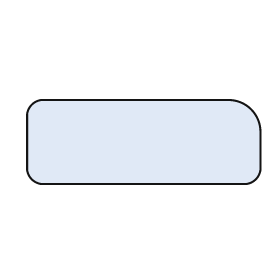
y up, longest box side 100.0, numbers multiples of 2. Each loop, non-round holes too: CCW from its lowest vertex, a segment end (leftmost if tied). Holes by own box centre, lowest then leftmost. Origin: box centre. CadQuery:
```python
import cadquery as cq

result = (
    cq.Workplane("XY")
    .moveTo(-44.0, -18.0)
    .lineTo(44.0, -18.0)
    .threePointArc((48.0, -16.0), (50.0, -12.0))
    .lineTo(50.0, 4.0)
    .threePointArc((46.0, 14.0), (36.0, 18.0))
    .lineTo(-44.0, 18.0)
    .threePointArc((-48.0, 16.0), (-50.0, 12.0))
    .lineTo(-50.0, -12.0)
    .threePointArc((-48.0, -16.0), (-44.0, -18.0))
    .close()
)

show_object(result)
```